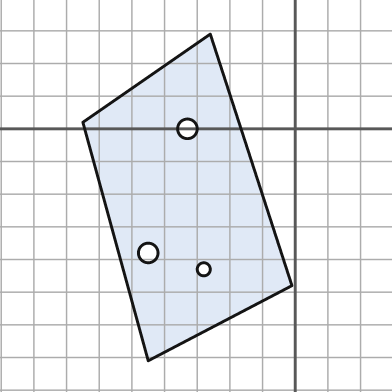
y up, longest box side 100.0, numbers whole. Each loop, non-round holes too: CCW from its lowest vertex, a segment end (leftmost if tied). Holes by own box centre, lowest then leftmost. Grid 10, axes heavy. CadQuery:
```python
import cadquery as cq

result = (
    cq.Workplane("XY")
    .moveTo(-45.0, -71.0)
    .lineTo(-1.0, -48.0)
    .lineTo(-26.0, 29.0)
    .lineTo(-65.0, 2.0)
    .close()
    .moveTo(-28.0, -43.0)
    .circle(2.0)
    .moveTo(-45.0, -38.0)
    .circle(3.0)
    .moveTo(-33.0, 0.0)
    .circle(3.0)
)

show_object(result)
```